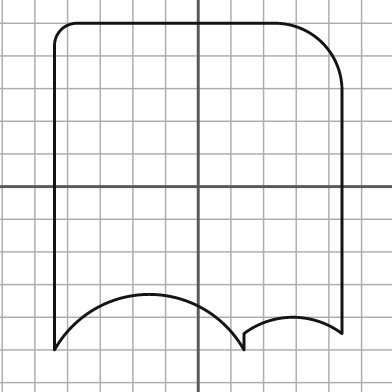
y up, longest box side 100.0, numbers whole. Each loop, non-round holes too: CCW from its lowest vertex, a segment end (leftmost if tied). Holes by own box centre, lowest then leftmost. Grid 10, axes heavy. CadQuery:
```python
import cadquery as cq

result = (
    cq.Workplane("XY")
    .moveTo(-44.0, -50.0)
    .threePointArc((-15.0, -33.0), (14.0, -50.0))
    .lineTo(14.0, -45.0)
    .threePointArc((29.0, -40.0), (44.0, -45.0))
    .lineTo(44.0, 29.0)
    .threePointArc((38.0, 44.0), (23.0, 50.0))
    .lineTo(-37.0, 50.0)
    .threePointArc((-42.0, 48.0), (-44.0, 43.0))
    .close()
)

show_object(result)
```